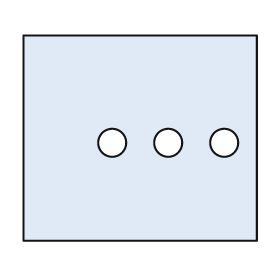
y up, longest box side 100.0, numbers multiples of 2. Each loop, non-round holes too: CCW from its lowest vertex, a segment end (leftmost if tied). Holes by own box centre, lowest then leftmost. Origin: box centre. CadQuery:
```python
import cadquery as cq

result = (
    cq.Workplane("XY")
    .moveTo(-50.0, -44.0)
    .lineTo(50.0, -44.0)
    .lineTo(50.0, 44.0)
    .lineTo(-50.0, 44.0)
    .close()
    .moveTo(-12.0, -2.0)
    .circle(6.0)
    .moveTo(12.0, -2.0)
    .circle(6.0)
    .moveTo(36.0, -2.0)
    .circle(6.0)
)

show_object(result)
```